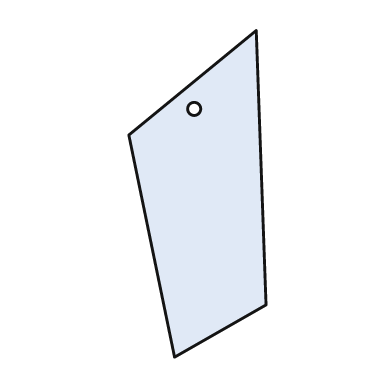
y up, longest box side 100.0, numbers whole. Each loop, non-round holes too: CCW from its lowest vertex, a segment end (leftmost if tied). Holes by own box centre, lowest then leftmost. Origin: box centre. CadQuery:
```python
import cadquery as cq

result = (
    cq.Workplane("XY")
    .moveTo(-7.0, -50.0)
    .lineTo(21.0, -34.0)
    .lineTo(18.0, 50.0)
    .lineTo(-21.0, 18.0)
    .close()
    .moveTo(-1.0, 26.0)
    .circle(2.0)
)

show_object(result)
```